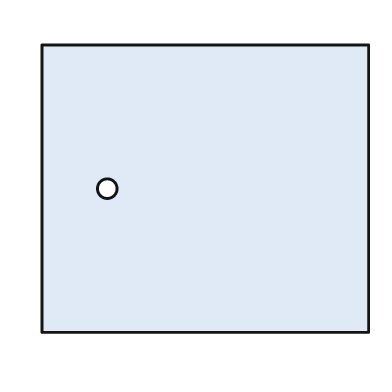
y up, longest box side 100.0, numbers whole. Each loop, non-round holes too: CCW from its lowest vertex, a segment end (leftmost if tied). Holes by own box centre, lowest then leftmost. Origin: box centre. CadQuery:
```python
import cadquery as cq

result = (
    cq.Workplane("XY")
    .moveTo(-50.0, -44.0)
    .lineTo(50.0, -44.0)
    .lineTo(50.0, 44.0)
    .lineTo(-50.0, 44.0)
    .close()
    .moveTo(-30.0, 0.0)
    .circle(3.0)
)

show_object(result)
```